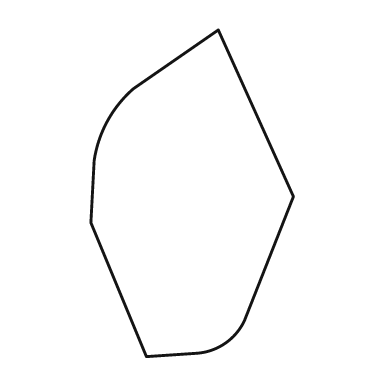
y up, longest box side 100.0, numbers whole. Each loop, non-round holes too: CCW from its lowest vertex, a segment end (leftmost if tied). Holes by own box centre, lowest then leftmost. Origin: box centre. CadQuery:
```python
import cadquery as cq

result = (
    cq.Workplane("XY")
    .moveTo(-14.0, -50.0)
    .lineTo(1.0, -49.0)
    .threePointArc((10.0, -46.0), (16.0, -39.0))
    .lineTo(31.0, -1.0)
    .lineTo(8.0, 50.0)
    .lineTo(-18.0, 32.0)
    .threePointArc((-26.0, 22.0), (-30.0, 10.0))
    .lineTo(-31.0, -9.0)
    .close()
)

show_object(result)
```